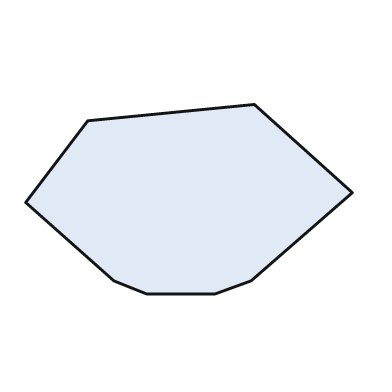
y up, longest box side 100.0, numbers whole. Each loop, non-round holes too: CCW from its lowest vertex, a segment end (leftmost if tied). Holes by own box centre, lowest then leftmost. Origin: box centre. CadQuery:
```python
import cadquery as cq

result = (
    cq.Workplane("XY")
    .moveTo(-13.0, -29.0)
    .lineTo(8.0, -29.0)
    .lineTo(19.0, -25.0)
    .lineTo(50.0, 2.0)
    .lineTo(20.0, 29.0)
    .lineTo(-31.0, 24.0)
    .lineTo(-50.0, -1.0)
    .lineTo(-23.0, -25.0)
    .close()
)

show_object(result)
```